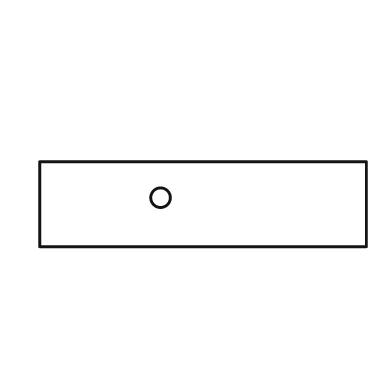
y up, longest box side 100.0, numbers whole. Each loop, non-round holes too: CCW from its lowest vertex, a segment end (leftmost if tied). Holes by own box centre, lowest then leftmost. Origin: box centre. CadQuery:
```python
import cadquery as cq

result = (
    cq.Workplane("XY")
    .moveTo(-50.0, -13.0)
    .lineTo(50.0, -13.0)
    .lineTo(50.0, 13.0)
    .lineTo(-50.0, 13.0)
    .close()
    .moveTo(-13.0, 2.0)
    .circle(3.0)
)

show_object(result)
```